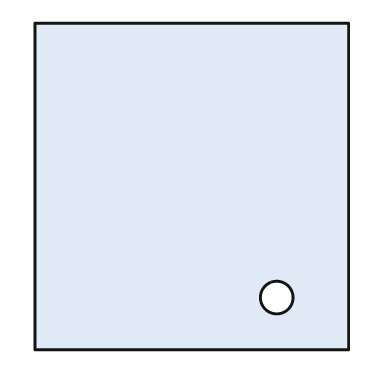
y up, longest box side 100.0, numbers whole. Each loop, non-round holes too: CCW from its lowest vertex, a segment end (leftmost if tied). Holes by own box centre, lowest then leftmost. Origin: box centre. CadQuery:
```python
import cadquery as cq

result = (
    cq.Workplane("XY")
    .moveTo(-48.0, -50.0)
    .lineTo(48.0, -50.0)
    .lineTo(48.0, 50.0)
    .lineTo(-48.0, 50.0)
    .close()
    .moveTo(26.0, -34.0)
    .circle(5.0)
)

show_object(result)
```